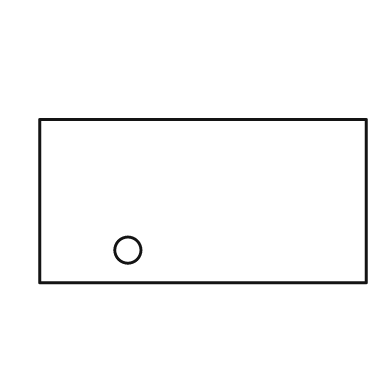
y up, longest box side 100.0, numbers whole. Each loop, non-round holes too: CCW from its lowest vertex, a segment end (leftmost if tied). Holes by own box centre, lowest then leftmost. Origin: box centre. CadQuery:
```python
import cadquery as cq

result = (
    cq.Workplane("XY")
    .moveTo(-50.0, -25.0)
    .lineTo(50.0, -25.0)
    .lineTo(50.0, 25.0)
    .lineTo(-50.0, 25.0)
    .close()
    .moveTo(-23.0, -15.0)
    .circle(4.0)
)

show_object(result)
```